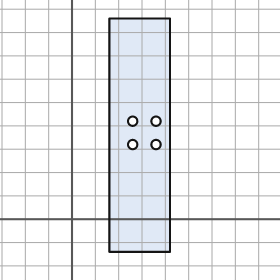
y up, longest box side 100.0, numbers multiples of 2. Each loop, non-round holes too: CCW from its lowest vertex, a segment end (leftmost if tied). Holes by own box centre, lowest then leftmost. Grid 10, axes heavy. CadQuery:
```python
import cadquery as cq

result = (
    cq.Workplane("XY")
    .moveTo(16.0, -14.0)
    .lineTo(42.0, -14.0)
    .lineTo(42.0, 86.0)
    .lineTo(16.0, 86.0)
    .close()
    .moveTo(26.0, 32.0)
    .circle(2.0)
    .moveTo(36.0, 32.0)
    .circle(2.0)
    .moveTo(26.0, 42.0)
    .circle(2.0)
    .moveTo(36.0, 42.0)
    .circle(2.0)
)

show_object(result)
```